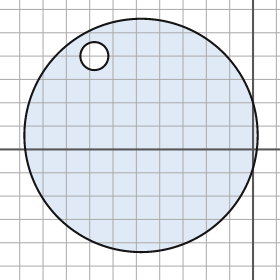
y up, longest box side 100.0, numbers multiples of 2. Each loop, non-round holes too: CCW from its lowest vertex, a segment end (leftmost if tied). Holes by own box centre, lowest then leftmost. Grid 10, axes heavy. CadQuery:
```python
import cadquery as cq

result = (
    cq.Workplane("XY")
    .moveTo(-48.0, 6.0)
    .circle(50.0)
    .moveTo(-68.0, 40.0)
    .circle(6.0)
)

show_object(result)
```